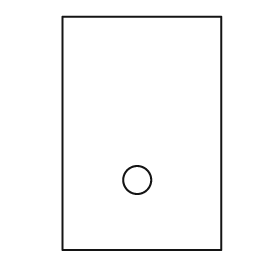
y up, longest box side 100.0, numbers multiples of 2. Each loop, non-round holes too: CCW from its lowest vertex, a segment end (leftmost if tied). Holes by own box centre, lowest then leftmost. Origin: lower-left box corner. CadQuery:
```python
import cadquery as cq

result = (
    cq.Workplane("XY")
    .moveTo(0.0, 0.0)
    .lineTo(68.0, 0.0)
    .lineTo(68.0, 100.0)
    .lineTo(0.0, 100.0)
    .close()
    .moveTo(32.0, 30.0)
    .circle(6.0)
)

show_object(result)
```